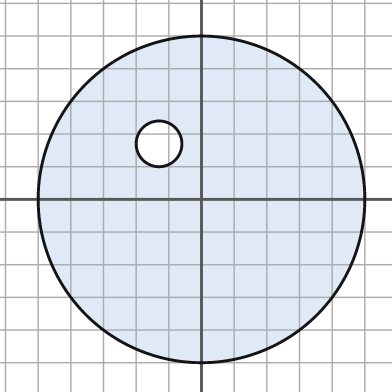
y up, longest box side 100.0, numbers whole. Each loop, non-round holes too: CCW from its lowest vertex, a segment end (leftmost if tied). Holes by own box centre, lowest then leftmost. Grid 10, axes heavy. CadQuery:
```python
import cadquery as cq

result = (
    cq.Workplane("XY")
    .moveTo(0.0, 0.0)
    .circle(50.0)
    .moveTo(-13.0, 17.0)
    .circle(7.0)
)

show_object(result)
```